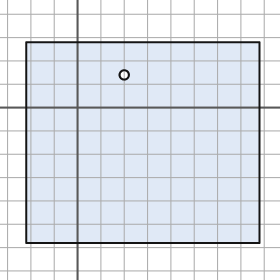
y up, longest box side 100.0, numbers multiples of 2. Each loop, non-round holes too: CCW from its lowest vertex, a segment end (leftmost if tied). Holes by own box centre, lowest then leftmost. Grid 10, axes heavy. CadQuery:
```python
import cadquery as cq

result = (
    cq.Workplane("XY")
    .moveTo(-22.0, -58.0)
    .lineTo(78.0, -58.0)
    .lineTo(78.0, 28.0)
    .lineTo(-22.0, 28.0)
    .close()
    .moveTo(20.0, 14.0)
    .circle(2.0)
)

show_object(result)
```